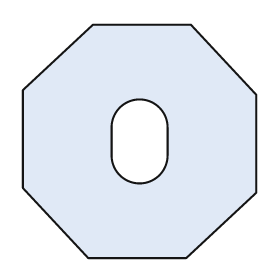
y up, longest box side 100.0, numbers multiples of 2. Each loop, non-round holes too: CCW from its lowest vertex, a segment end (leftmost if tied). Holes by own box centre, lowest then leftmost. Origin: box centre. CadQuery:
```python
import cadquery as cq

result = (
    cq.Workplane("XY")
    .moveTo(-22.0, -50.0)
    .lineTo(20.0, -50.0)
    .lineTo(50.0, -22.0)
    .lineTo(50.0, 20.0)
    .lineTo(22.0, 50.0)
    .lineTo(-20.0, 50.0)
    .lineTo(-50.0, 22.0)
    .lineTo(-50.0, -20.0)
    .close()
    .moveTo(-12.0, -6.0)
    .threePointArc((0.0, -18.0), (12.0, -6.0))
    .lineTo(12.0, 6.0)
    .threePointArc((0.0, 18.0), (-12.0, 6.0))
    .close()
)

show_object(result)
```